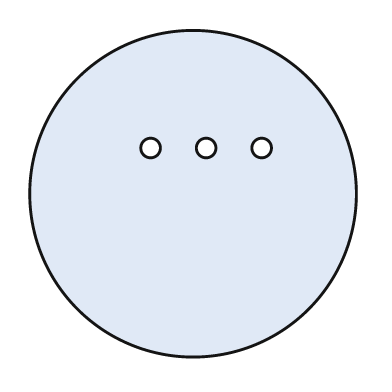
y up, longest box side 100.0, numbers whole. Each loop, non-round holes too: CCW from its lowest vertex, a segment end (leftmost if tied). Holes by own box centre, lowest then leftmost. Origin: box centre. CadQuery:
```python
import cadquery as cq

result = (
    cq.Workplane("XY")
    .moveTo(0.0, 0.0)
    .circle(50.0)
    .moveTo(-13.0, 14.0)
    .circle(3.0)
    .moveTo(4.0, 14.0)
    .circle(3.0)
    .moveTo(21.0, 14.0)
    .circle(3.0)
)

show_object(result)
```